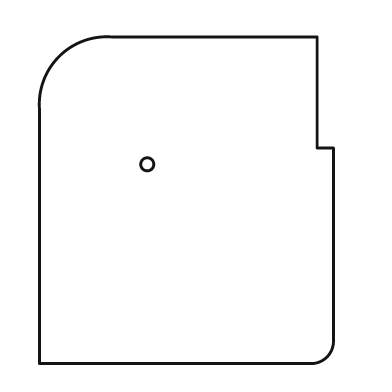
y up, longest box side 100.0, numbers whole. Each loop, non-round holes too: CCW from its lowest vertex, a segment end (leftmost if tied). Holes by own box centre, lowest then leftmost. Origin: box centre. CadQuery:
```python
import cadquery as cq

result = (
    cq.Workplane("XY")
    .moveTo(-45.0, -50.0)
    .lineTo(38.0, -50.0)
    .threePointArc((43.0, -48.0), (45.0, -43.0))
    .lineTo(45.0, 16.0)
    .lineTo(40.0, 16.0)
    .lineTo(40.0, 50.0)
    .lineTo(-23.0, 50.0)
    .threePointArc((-39.0, 44.0), (-45.0, 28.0))
    .close()
    .moveTo(-12.0, 11.0)
    .circle(2.0)
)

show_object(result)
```